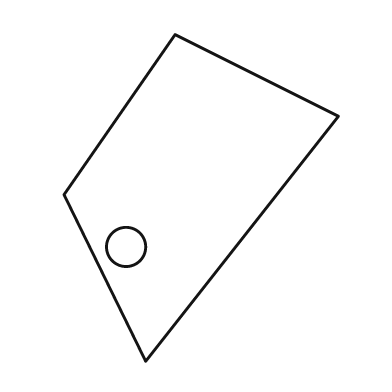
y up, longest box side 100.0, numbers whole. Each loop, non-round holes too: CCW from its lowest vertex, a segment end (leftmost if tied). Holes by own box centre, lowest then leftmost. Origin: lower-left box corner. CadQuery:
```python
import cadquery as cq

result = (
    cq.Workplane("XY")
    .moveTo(25.0, 0.0)
    .lineTo(84.0, 75.0)
    .lineTo(34.0, 100.0)
    .lineTo(0.0, 51.0)
    .close()
    .moveTo(19.0, 35.0)
    .circle(6.0)
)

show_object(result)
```